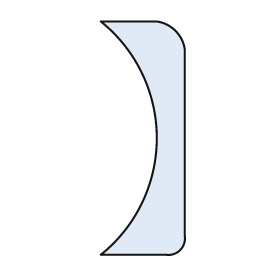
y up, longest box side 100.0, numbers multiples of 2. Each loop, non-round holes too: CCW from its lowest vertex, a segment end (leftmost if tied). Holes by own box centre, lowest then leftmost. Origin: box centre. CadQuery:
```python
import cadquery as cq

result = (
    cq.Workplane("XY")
    .moveTo(-18.0, -50.0)
    .lineTo(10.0, -50.0)
    .threePointArc((16.0, -48.0), (18.0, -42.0))
    .lineTo(18.0, 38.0)
    .threePointArc((14.0, 46.0), (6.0, 50.0))
    .lineTo(-18.0, 50.0)
    .threePointArc((6.0, 0.0), (-18.0, -50.0))
    .close()
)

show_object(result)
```